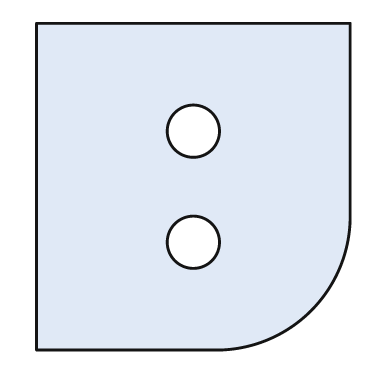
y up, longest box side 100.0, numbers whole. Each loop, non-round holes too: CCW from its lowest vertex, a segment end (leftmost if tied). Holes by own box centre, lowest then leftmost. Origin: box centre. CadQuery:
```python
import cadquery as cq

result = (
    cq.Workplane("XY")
    .moveTo(-48.0, -50.0)
    .lineTo(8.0, -50.0)
    .threePointArc((36.0, -38.0), (48.0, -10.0))
    .lineTo(48.0, 50.0)
    .lineTo(-48.0, 50.0)
    .close()
    .moveTo(0.0, -17.0)
    .circle(8.0)
    .moveTo(0.0, 17.0)
    .circle(8.0)
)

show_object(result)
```